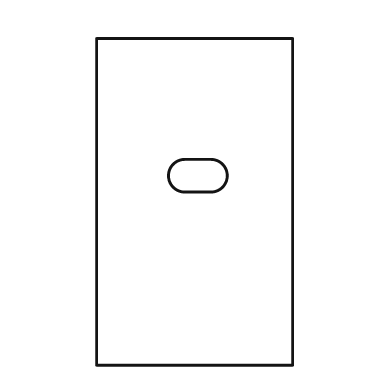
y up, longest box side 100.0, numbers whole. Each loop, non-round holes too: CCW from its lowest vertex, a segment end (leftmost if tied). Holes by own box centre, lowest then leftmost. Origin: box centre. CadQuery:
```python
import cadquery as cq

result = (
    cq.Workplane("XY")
    .moveTo(-30.0, -50.0)
    .lineTo(30.0, -50.0)
    .lineTo(30.0, 50.0)
    .lineTo(-30.0, 50.0)
    .close()
    .moveTo(-3.0, 3.0)
    .lineTo(5.0, 3.0)
    .threePointArc((10.0, 8.0), (5.0, 13.0))
    .lineTo(-3.0, 13.0)
    .threePointArc((-8.0, 8.0), (-3.0, 3.0))
    .close()
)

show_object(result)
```